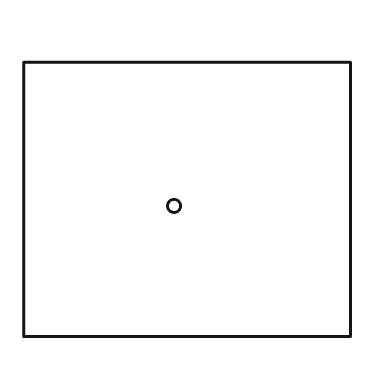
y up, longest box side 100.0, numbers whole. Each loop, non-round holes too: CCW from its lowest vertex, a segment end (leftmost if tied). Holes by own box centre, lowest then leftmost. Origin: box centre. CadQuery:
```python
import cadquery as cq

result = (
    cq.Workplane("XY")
    .moveTo(-50.0, -42.0)
    .lineTo(50.0, -42.0)
    .lineTo(50.0, 42.0)
    .lineTo(-50.0, 42.0)
    .close()
    .moveTo(-4.0, -2.0)
    .circle(2.0)
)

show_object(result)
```